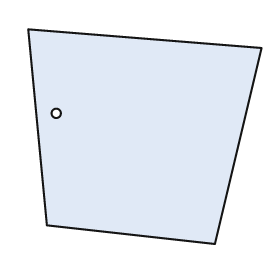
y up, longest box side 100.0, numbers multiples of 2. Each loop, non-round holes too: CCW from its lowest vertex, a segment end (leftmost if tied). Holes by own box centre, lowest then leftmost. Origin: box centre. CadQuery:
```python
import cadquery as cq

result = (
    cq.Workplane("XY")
    .moveTo(30.0, -46.0)
    .lineTo(50.0, 38.0)
    .lineTo(-50.0, 46.0)
    .lineTo(-42.0, -38.0)
    .close()
    .moveTo(-38.0, 10.0)
    .circle(2.0)
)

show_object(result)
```